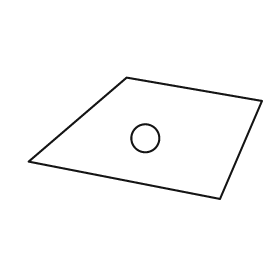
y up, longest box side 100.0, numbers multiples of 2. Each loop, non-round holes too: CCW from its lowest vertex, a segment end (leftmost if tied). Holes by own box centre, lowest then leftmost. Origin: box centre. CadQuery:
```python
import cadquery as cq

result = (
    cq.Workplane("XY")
    .moveTo(32.0, -26.0)
    .lineTo(50.0, 16.0)
    .lineTo(-8.0, 26.0)
    .lineTo(-50.0, -10.0)
    .close()
    .moveTo(0.0, 0.0)
    .circle(6.0)
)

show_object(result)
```